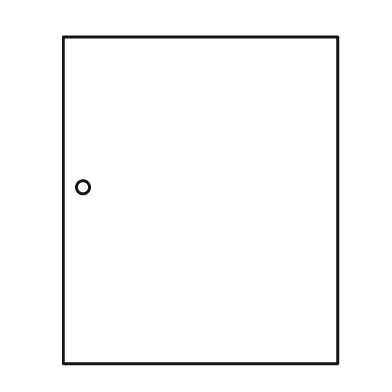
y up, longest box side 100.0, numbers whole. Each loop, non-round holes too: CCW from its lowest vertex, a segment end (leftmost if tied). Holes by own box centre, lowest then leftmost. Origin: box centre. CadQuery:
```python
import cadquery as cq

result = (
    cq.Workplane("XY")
    .moveTo(-42.0, -50.0)
    .lineTo(42.0, -50.0)
    .lineTo(42.0, 50.0)
    .lineTo(-42.0, 50.0)
    .close()
    .moveTo(-36.0, 4.0)
    .circle(2.0)
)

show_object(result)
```